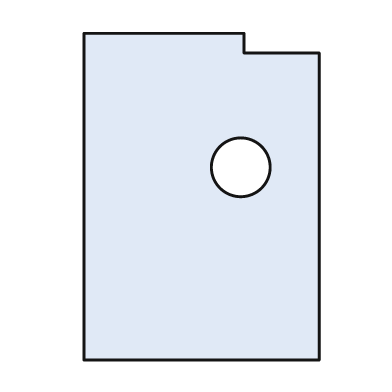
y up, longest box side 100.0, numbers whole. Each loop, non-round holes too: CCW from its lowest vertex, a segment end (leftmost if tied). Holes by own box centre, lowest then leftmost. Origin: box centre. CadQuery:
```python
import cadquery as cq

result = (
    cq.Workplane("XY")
    .moveTo(-36.0, -50.0)
    .lineTo(36.0, -50.0)
    .lineTo(36.0, 44.0)
    .lineTo(13.0, 44.0)
    .lineTo(13.0, 50.0)
    .lineTo(-36.0, 50.0)
    .close()
    .moveTo(12.0, 9.0)
    .circle(9.0)
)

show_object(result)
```